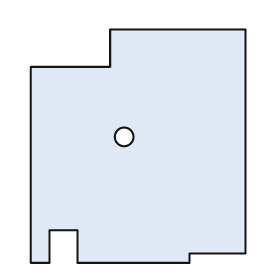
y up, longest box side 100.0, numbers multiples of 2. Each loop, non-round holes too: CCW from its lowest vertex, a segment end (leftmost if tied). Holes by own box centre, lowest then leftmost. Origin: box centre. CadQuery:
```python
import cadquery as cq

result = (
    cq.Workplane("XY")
    .moveTo(-46.0, -50.0)
    .lineTo(-38.0, -50.0)
    .lineTo(-38.0, -36.0)
    .lineTo(-26.0, -36.0)
    .lineTo(-26.0, -50.0)
    .lineTo(22.0, -50.0)
    .lineTo(22.0, -46.0)
    .lineTo(46.0, -46.0)
    .lineTo(46.0, 50.0)
    .lineTo(-12.0, 50.0)
    .lineTo(-12.0, 34.0)
    .lineTo(-46.0, 34.0)
    .close()
    .moveTo(-6.0, 4.0)
    .circle(4.0)
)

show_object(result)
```